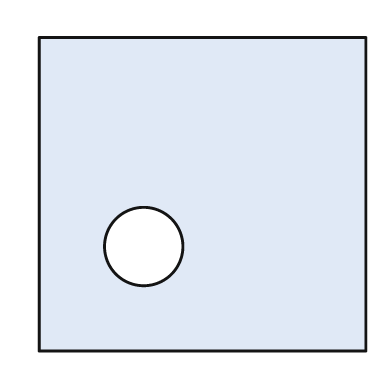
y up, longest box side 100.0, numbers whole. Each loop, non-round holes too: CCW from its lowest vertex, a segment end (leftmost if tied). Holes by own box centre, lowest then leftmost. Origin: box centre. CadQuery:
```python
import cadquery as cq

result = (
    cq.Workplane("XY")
    .moveTo(-50.0, -48.0)
    .lineTo(50.0, -48.0)
    .lineTo(50.0, 48.0)
    .lineTo(-50.0, 48.0)
    .close()
    .moveTo(-18.0, -16.0)
    .circle(12.0)
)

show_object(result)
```